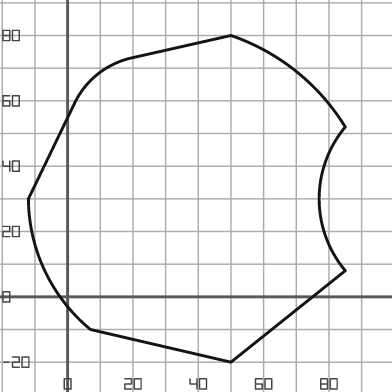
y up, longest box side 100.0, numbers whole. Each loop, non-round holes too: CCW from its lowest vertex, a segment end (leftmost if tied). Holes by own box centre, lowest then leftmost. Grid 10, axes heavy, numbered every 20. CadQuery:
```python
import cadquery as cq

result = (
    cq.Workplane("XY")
    .moveTo(50.0, -20.0)
    .lineTo(85.0, 8.0)
    .threePointArc((77.0, 30.0), (85.0, 52.0))
    .threePointArc((70.0, 69.0), (50.0, 80.0))
    .lineTo(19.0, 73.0)
    .threePointArc((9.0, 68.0), (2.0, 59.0))
    .lineTo(-12.0, 30.0)
    .threePointArc((-7.0, 8.0), (7.0, -10.0))
    .close()
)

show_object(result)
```